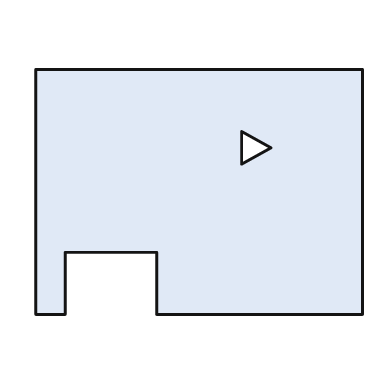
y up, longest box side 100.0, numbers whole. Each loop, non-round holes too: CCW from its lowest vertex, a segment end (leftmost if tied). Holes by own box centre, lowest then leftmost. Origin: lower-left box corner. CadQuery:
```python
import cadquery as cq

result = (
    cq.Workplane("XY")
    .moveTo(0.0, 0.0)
    .lineTo(9.0, 0.0)
    .lineTo(9.0, 19.0)
    .lineTo(37.0, 19.0)
    .lineTo(37.0, 0.0)
    .lineTo(100.0, 0.0)
    .lineTo(100.0, 75.0)
    .lineTo(0.0, 75.0)
    .close()
    .moveTo(63.0, 46.0)
    .lineTo(72.0, 51.0)
    .lineTo(63.0, 56.0)
    .close()
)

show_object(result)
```